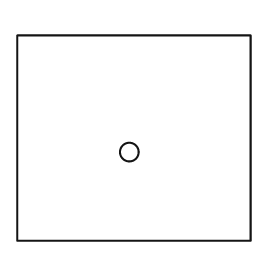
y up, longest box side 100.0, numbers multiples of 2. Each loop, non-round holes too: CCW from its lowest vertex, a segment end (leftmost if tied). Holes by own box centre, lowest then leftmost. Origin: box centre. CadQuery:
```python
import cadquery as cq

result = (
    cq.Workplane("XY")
    .moveTo(-50.0, -44.0)
    .lineTo(50.0, -44.0)
    .lineTo(50.0, 44.0)
    .lineTo(-50.0, 44.0)
    .close()
    .moveTo(-2.0, -6.0)
    .circle(4.0)
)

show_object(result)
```